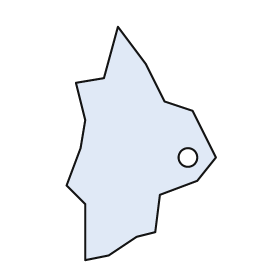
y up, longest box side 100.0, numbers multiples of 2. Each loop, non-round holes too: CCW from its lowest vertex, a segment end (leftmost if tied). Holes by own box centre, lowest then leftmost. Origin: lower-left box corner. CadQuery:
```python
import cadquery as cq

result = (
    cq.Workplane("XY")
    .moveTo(8.0, 0.0)
    .lineTo(18.0, 2.0)
    .lineTo(30.0, 10.0)
    .lineTo(38.0, 12.0)
    .lineTo(40.0, 28.0)
    .lineTo(56.0, 34.0)
    .lineTo(64.0, 44.0)
    .lineTo(54.0, 64.0)
    .lineTo(42.0, 68.0)
    .lineTo(34.0, 84.0)
    .lineTo(22.0, 100.0)
    .lineTo(16.0, 78.0)
    .lineTo(4.0, 76.0)
    .lineTo(8.0, 60.0)
    .lineTo(6.0, 48.0)
    .lineTo(0.0, 32.0)
    .lineTo(8.0, 24.0)
    .close()
    .moveTo(52.0, 44.0)
    .circle(4.0)
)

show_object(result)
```